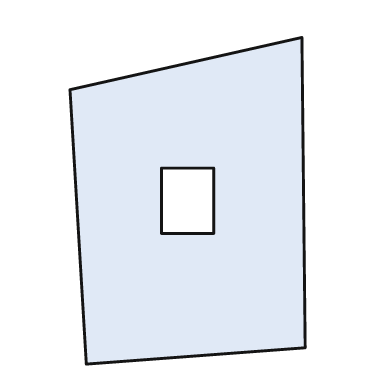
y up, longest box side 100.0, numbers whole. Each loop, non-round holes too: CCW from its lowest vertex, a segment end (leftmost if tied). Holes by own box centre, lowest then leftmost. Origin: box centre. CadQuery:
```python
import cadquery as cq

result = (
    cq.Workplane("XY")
    .moveTo(-31.0, -50.0)
    .lineTo(36.0, -45.0)
    .lineTo(35.0, 50.0)
    .lineTo(-36.0, 34.0)
    .close()
    .moveTo(-8.0, -10.0)
    .lineTo(8.0, -10.0)
    .lineTo(8.0, 10.0)
    .lineTo(-8.0, 10.0)
    .close()
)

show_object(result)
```